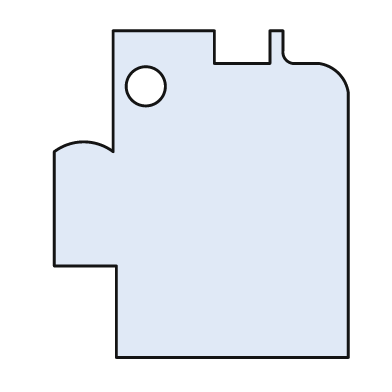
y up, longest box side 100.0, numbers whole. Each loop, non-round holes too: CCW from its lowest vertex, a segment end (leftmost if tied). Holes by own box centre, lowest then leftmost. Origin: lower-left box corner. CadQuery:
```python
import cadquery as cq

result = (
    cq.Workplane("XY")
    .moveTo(19.0, 0.0)
    .lineTo(90.0, 0.0)
    .lineTo(90.0, 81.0)
    .threePointArc((87.0, 87.0), (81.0, 90.0))
    .lineTo(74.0, 90.0)
    .threePointArc((71.0, 91.0), (70.0, 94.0))
    .lineTo(70.0, 100.0)
    .lineTo(66.0, 100.0)
    .lineTo(66.0, 90.0)
    .lineTo(49.0, 90.0)
    .lineTo(49.0, 100.0)
    .lineTo(18.0, 100.0)
    .lineTo(18.0, 63.0)
    .threePointArc((9.0, 66.0), (0.0, 63.0))
    .lineTo(0.0, 28.0)
    .lineTo(19.0, 28.0)
    .close()
    .moveTo(28.0, 83.0)
    .circle(6.0)
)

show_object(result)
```